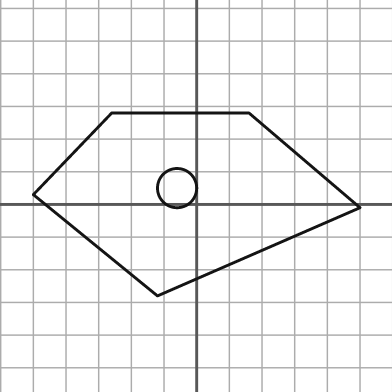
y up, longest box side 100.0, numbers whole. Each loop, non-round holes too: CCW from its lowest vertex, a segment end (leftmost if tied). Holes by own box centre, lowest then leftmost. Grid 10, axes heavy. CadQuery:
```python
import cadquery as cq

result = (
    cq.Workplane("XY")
    .moveTo(-12.0, -28.0)
    .lineTo(50.0, -1.0)
    .lineTo(16.0, 28.0)
    .lineTo(-26.0, 28.0)
    .lineTo(-50.0, 3.0)
    .close()
    .moveTo(-6.0, 5.0)
    .circle(6.0)
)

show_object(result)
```